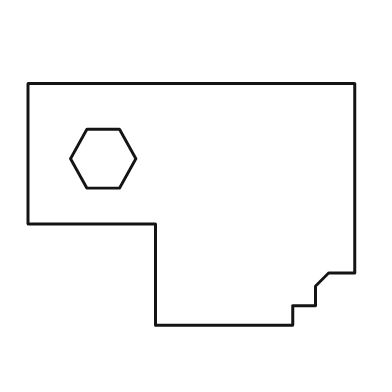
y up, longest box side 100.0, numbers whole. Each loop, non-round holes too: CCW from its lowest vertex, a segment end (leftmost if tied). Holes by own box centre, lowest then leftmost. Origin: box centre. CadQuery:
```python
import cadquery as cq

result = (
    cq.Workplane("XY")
    .moveTo(-11.0, -37.0)
    .lineTo(31.0, -37.0)
    .lineTo(31.0, -31.0)
    .lineTo(38.0, -31.0)
    .lineTo(38.0, -25.0)
    .lineTo(42.0, -21.0)
    .lineTo(50.0, -21.0)
    .lineTo(50.0, 37.0)
    .lineTo(-50.0, 37.0)
    .lineTo(-50.0, -6.0)
    .lineTo(-11.0, -6.0)
    .close()
    .moveTo(-32.0, 5.0)
    .lineTo(-22.0, 5.0)
    .lineTo(-17.0, 14.0)
    .lineTo(-22.0, 23.0)
    .lineTo(-32.0, 23.0)
    .lineTo(-37.0, 14.0)
    .close()
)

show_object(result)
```